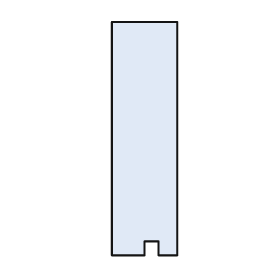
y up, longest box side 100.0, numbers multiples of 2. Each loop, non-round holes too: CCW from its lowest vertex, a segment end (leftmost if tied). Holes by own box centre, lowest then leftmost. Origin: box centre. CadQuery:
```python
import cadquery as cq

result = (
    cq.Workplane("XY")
    .moveTo(-14.0, -50.0)
    .lineTo(0.0, -50.0)
    .lineTo(0.0, -44.0)
    .lineTo(6.0, -44.0)
    .lineTo(6.0, -50.0)
    .lineTo(14.0, -50.0)
    .lineTo(14.0, 50.0)
    .lineTo(-14.0, 50.0)
    .close()
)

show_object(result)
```